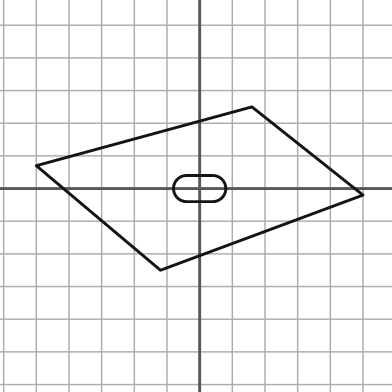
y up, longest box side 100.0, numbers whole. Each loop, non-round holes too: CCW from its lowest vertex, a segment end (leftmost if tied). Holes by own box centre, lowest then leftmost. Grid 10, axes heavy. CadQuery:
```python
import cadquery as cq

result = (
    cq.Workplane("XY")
    .moveTo(-12.0, -25.0)
    .lineTo(50.0, -2.0)
    .lineTo(16.0, 25.0)
    .lineTo(-50.0, 7.0)
    .close()
    .moveTo(-4.0, -4.0)
    .lineTo(4.0, -4.0)
    .threePointArc((8.0, 0.0), (4.0, 4.0))
    .lineTo(-4.0, 4.0)
    .threePointArc((-8.0, 0.0), (-4.0, -4.0))
    .close()
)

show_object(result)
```